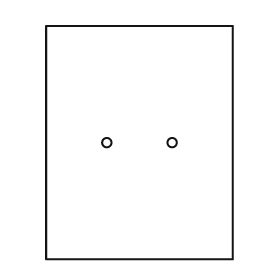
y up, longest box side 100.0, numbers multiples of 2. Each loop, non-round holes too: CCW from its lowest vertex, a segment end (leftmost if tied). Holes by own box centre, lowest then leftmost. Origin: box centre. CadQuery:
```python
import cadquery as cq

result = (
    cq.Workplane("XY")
    .moveTo(-40.0, -50.0)
    .lineTo(40.0, -50.0)
    .lineTo(40.0, 50.0)
    .lineTo(-40.0, 50.0)
    .close()
    .moveTo(-14.0, 0.0)
    .circle(2.0)
    .moveTo(14.0, 0.0)
    .circle(2.0)
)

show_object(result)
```